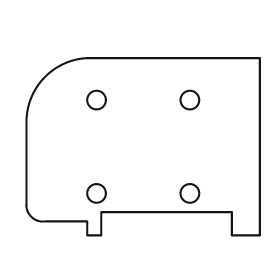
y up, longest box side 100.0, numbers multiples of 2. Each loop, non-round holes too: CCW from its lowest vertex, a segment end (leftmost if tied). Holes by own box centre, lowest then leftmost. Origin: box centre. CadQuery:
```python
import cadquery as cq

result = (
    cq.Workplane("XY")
    .moveTo(-24.0, -38.0)
    .lineTo(-18.0, -38.0)
    .lineTo(-18.0, -28.0)
    .lineTo(38.0, -28.0)
    .lineTo(38.0, -38.0)
    .lineTo(50.0, -38.0)
    .lineTo(50.0, 38.0)
    .lineTo(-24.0, 38.0)
    .threePointArc((-42.0, 30.0), (-50.0, 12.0))
    .lineTo(-50.0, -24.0)
    .threePointArc((-48.0, -30.0), (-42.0, -32.0))
    .lineTo(-24.0, -32.0)
    .close()
    .moveTo(-20.0, -20.0)
    .circle(4.0)
    .moveTo(20.0, -20.0)
    .circle(4.0)
    .moveTo(-20.0, 20.0)
    .circle(4.0)
    .moveTo(20.0, 20.0)
    .circle(4.0)
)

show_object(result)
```